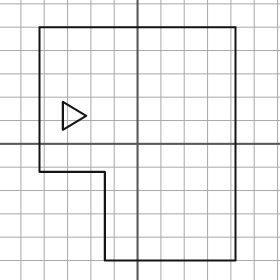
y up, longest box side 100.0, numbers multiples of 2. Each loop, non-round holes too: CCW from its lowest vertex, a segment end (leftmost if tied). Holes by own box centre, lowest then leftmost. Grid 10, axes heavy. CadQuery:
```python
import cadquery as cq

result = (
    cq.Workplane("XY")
    .moveTo(-14.0, -50.0)
    .lineTo(42.0, -50.0)
    .lineTo(42.0, 50.0)
    .lineTo(-42.0, 50.0)
    .lineTo(-42.0, -12.0)
    .lineTo(-14.0, -12.0)
    .close()
    .moveTo(-32.0, 6.0)
    .lineTo(-22.0, 12.0)
    .lineTo(-32.0, 18.0)
    .close()
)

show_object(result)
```